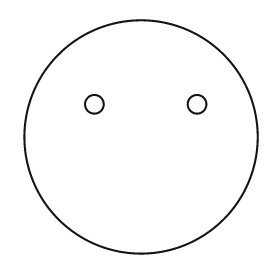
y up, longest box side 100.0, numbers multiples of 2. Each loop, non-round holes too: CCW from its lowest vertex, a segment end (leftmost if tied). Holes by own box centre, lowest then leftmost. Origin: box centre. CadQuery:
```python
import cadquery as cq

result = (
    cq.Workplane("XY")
    .moveTo(0.0, 0.0)
    .circle(50.0)
    .moveTo(-20.0, 14.0)
    .circle(4.0)
    .moveTo(24.0, 14.0)
    .circle(4.0)
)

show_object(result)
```